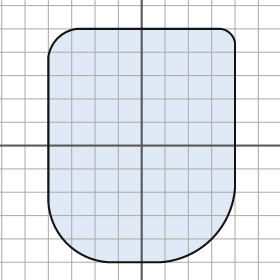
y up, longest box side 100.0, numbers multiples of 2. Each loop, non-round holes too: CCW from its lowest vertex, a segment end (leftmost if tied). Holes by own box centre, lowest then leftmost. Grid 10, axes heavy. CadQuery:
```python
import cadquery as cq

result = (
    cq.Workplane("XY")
    .moveTo(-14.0, -50.0)
    .lineTo(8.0, -50.0)
    .threePointArc((30.0, -40.0), (40.0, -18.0))
    .lineTo(40.0, 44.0)
    .threePointArc((38.0, 48.0), (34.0, 50.0))
    .lineTo(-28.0, 50.0)
    .threePointArc((-36.0, 46.0), (-40.0, 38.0))
    .lineTo(-40.0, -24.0)
    .threePointArc((-32.0, -42.0), (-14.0, -50.0))
    .close()
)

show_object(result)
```